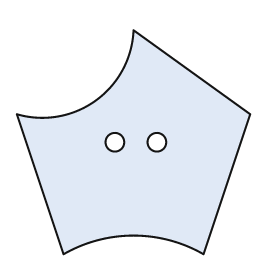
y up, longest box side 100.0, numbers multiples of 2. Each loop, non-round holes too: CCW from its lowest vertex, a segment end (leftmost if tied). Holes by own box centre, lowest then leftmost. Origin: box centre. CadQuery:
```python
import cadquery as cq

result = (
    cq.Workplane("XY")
    .moveTo(-30.0, -48.0)
    .threePointArc((0.0, -40.0), (30.0, -48.0))
    .lineTo(50.0, 12.0)
    .lineTo(0.0, 48.0)
    .threePointArc((-16.0, 18.0), (-50.0, 12.0))
    .close()
    .moveTo(-8.0, 0.0)
    .circle(4.0)
    .moveTo(10.0, 0.0)
    .circle(4.0)
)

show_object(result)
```